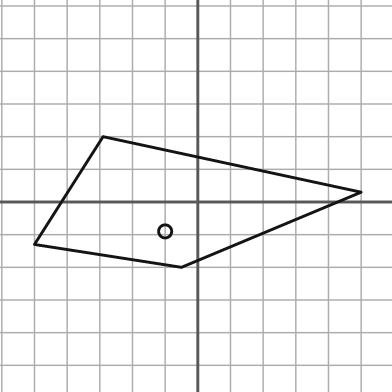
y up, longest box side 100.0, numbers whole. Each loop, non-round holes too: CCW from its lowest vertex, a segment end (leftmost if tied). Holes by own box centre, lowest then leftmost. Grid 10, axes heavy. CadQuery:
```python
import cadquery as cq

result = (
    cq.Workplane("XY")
    .moveTo(-5.0, -20.0)
    .lineTo(50.0, 3.0)
    .lineTo(-29.0, 20.0)
    .lineTo(-50.0, -13.0)
    .close()
    .moveTo(-10.0, -9.0)
    .circle(2.0)
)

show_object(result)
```